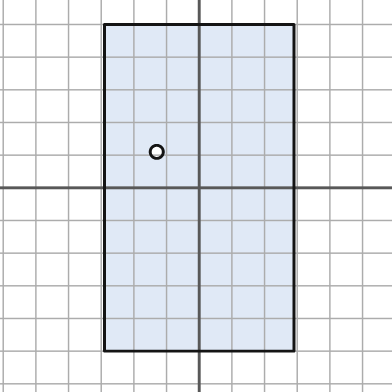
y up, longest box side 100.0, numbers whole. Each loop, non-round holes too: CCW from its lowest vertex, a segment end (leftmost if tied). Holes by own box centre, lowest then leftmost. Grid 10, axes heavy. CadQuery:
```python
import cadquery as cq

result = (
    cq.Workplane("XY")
    .moveTo(-29.0, -50.0)
    .lineTo(29.0, -50.0)
    .lineTo(29.0, 50.0)
    .lineTo(-29.0, 50.0)
    .close()
    .moveTo(-13.0, 11.0)
    .circle(2.0)
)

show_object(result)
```